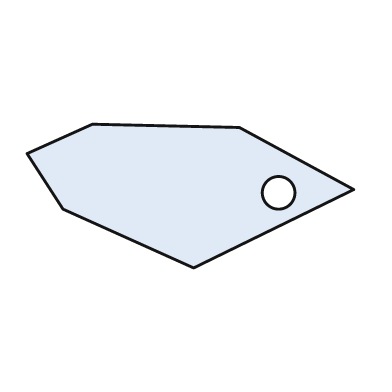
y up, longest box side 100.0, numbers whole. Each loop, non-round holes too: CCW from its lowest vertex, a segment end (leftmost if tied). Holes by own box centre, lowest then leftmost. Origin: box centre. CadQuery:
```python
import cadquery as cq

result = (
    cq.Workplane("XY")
    .moveTo(1.0, -22.0)
    .lineTo(50.0, 2.0)
    .lineTo(15.0, 21.0)
    .lineTo(-30.0, 22.0)
    .lineTo(-50.0, 13.0)
    .lineTo(-39.0, -4.0)
    .close()
    .moveTo(27.0, 1.0)
    .circle(5.0)
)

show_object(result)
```